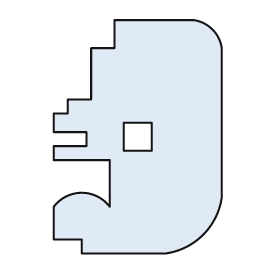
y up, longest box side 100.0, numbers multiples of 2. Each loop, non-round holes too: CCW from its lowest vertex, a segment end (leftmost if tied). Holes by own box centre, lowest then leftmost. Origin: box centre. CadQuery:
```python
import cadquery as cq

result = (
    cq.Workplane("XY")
    .moveTo(-24.0, -50.0)
    .lineTo(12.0, -50.0)
    .threePointArc((28.0, -42.0), (36.0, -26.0))
    .lineTo(36.0, 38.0)
    .threePointArc((32.0, 46.0), (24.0, 50.0))
    .lineTo(-10.0, 50.0)
    .lineTo(-10.0, 38.0)
    .lineTo(-20.0, 38.0)
    .lineTo(-20.0, 16.0)
    .lineTo(-30.0, 16.0)
    .lineTo(-30.0, 10.0)
    .lineTo(-36.0, 10.0)
    .lineTo(-36.0, 2.0)
    .lineTo(-22.0, 2.0)
    .lineTo(-22.0, -4.0)
    .lineTo(-36.0, -4.0)
    .lineTo(-36.0, -10.0)
    .lineTo(-12.0, -10.0)
    .lineTo(-12.0, -30.0)
    .threePointArc((-24.0, -24.0), (-36.0, -30.0))
    .lineTo(-36.0, -44.0)
    .lineTo(-24.0, -44.0)
    .close()
    .moveTo(-6.0, -6.0)
    .lineTo(6.0, -6.0)
    .lineTo(6.0, 6.0)
    .lineTo(-6.0, 6.0)
    .close()
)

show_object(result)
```